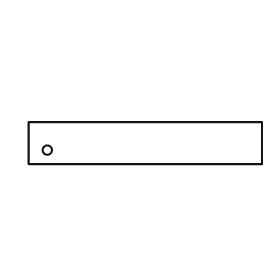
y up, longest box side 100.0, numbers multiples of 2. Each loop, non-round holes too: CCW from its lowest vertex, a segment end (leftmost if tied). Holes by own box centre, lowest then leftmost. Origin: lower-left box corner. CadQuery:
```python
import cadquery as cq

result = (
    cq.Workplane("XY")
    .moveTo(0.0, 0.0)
    .lineTo(100.0, 0.0)
    .lineTo(100.0, 18.0)
    .lineTo(0.0, 18.0)
    .close()
    .moveTo(8.0, 6.0)
    .circle(2.0)
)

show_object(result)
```